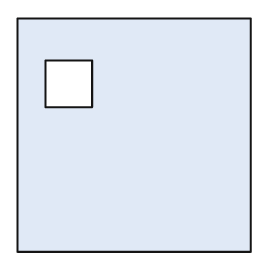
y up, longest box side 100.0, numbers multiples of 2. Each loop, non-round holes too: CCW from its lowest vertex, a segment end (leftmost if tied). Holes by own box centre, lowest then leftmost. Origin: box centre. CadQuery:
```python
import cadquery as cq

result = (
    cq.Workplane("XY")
    .moveTo(-50.0, -50.0)
    .lineTo(50.0, -50.0)
    .lineTo(50.0, 50.0)
    .lineTo(-50.0, 50.0)
    .close()
    .moveTo(-38.0, 12.0)
    .lineTo(-18.0, 12.0)
    .lineTo(-18.0, 32.0)
    .lineTo(-38.0, 32.0)
    .close()
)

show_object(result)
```